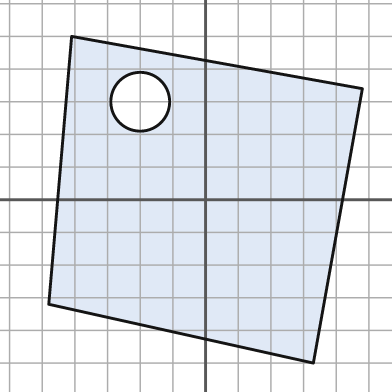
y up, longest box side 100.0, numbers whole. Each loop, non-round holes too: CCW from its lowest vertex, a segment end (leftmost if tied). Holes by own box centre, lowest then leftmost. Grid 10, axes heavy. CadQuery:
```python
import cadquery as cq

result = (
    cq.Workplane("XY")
    .moveTo(33.0, -50.0)
    .lineTo(48.0, 34.0)
    .lineTo(-41.0, 50.0)
    .lineTo(-48.0, -32.0)
    .close()
    .moveTo(-20.0, 30.0)
    .circle(9.0)
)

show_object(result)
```